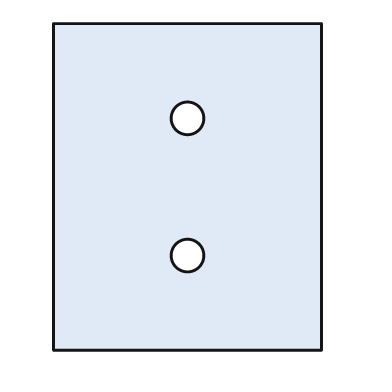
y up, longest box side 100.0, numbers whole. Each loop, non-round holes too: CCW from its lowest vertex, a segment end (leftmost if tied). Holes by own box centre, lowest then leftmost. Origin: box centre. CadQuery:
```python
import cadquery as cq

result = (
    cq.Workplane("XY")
    .moveTo(-41.0, -50.0)
    .lineTo(41.0, -50.0)
    .lineTo(41.0, 50.0)
    .lineTo(-41.0, 50.0)
    .close()
    .moveTo(0.0, -21.0)
    .circle(5.0)
    .moveTo(0.0, 21.0)
    .circle(5.0)
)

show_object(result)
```